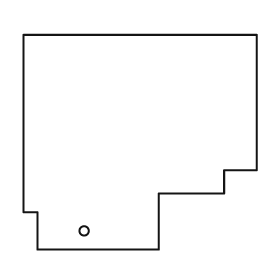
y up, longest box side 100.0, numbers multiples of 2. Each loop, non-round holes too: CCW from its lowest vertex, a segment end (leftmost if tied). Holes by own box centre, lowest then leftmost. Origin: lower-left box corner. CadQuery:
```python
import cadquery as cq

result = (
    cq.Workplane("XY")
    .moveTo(6.0, 0.0)
    .lineTo(58.0, 0.0)
    .lineTo(58.0, 24.0)
    .lineTo(86.0, 24.0)
    .lineTo(86.0, 34.0)
    .lineTo(100.0, 34.0)
    .lineTo(100.0, 92.0)
    .lineTo(0.0, 92.0)
    .lineTo(0.0, 16.0)
    .lineTo(6.0, 16.0)
    .close()
    .moveTo(26.0, 8.0)
    .circle(2.0)
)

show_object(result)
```